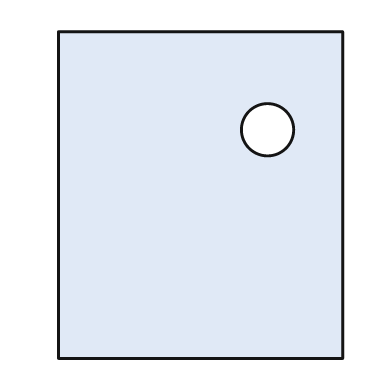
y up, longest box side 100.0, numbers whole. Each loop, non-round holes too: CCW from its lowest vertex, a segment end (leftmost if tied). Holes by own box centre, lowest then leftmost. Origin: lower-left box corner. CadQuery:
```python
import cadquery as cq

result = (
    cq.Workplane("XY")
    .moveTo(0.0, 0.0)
    .lineTo(87.0, 0.0)
    .lineTo(87.0, 100.0)
    .lineTo(0.0, 100.0)
    .close()
    .moveTo(64.0, 70.0)
    .circle(8.0)
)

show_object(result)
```